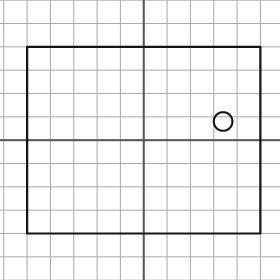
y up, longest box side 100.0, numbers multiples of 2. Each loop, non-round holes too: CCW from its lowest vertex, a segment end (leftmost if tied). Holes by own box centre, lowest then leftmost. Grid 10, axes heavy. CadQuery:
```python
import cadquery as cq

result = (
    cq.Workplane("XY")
    .moveTo(-50.0, -40.0)
    .lineTo(50.0, -40.0)
    .lineTo(50.0, 40.0)
    .lineTo(-50.0, 40.0)
    .close()
    .moveTo(34.0, 8.0)
    .circle(4.0)
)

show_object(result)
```